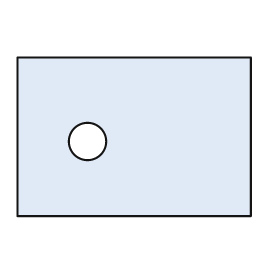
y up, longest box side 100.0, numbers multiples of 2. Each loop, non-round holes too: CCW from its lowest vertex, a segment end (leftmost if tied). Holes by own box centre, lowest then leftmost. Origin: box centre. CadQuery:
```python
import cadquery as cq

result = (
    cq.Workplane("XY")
    .moveTo(-50.0, -34.0)
    .lineTo(50.0, -34.0)
    .lineTo(50.0, 34.0)
    .lineTo(-50.0, 34.0)
    .close()
    .moveTo(-20.0, -2.0)
    .circle(8.0)
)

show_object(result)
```